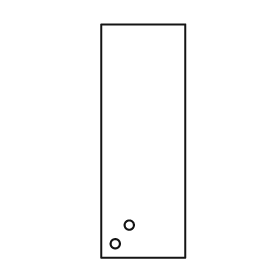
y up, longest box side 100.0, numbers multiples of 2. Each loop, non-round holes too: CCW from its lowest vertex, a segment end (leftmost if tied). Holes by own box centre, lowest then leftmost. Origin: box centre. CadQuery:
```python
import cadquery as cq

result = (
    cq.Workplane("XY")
    .moveTo(-18.0, -50.0)
    .lineTo(18.0, -50.0)
    .lineTo(18.0, 50.0)
    .lineTo(-18.0, 50.0)
    .close()
    .moveTo(-12.0, -44.0)
    .circle(2.0)
    .moveTo(-6.0, -36.0)
    .circle(2.0)
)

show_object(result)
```